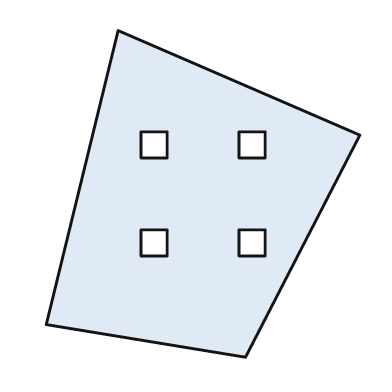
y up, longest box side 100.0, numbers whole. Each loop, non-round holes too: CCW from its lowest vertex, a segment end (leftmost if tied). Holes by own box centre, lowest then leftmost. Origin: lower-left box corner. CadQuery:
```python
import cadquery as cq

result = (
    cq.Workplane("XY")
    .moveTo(61.0, 0.0)
    .lineTo(96.0, 68.0)
    .lineTo(22.0, 100.0)
    .lineTo(0.0, 10.0)
    .close()
    .moveTo(29.0, 31.0)
    .lineTo(37.0, 31.0)
    .lineTo(37.0, 39.0)
    .lineTo(29.0, 39.0)
    .close()
    .moveTo(59.0, 31.0)
    .lineTo(67.0, 31.0)
    .lineTo(67.0, 39.0)
    .lineTo(59.0, 39.0)
    .close()
    .moveTo(29.0, 61.0)
    .lineTo(37.0, 61.0)
    .lineTo(37.0, 69.0)
    .lineTo(29.0, 69.0)
    .close()
    .moveTo(59.0, 61.0)
    .lineTo(67.0, 61.0)
    .lineTo(67.0, 69.0)
    .lineTo(59.0, 69.0)
    .close()
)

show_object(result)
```